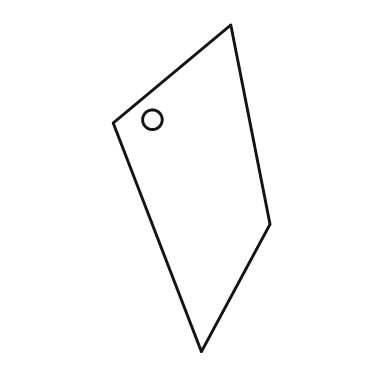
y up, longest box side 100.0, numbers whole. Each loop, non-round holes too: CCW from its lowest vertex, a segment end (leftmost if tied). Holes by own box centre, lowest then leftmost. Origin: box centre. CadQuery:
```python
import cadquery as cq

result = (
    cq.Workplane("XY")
    .moveTo(3.0, -50.0)
    .lineTo(24.0, -11.0)
    .lineTo(12.0, 50.0)
    .lineTo(-24.0, 20.0)
    .close()
    .moveTo(-12.0, 21.0)
    .circle(3.0)
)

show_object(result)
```